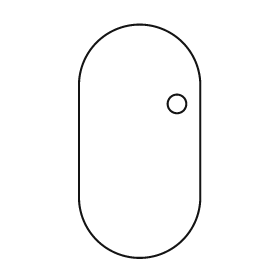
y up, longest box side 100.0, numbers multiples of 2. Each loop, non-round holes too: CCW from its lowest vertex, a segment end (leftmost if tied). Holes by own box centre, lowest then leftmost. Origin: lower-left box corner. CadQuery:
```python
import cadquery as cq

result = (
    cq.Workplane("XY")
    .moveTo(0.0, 26.0)
    .threePointArc((26.0, 0.0), (52.0, 26.0))
    .lineTo(52.0, 74.0)
    .threePointArc((26.0, 100.0), (0.0, 74.0))
    .close()
    .moveTo(42.0, 66.0)
    .circle(4.0)
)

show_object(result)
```